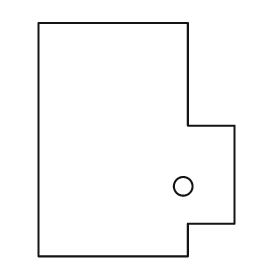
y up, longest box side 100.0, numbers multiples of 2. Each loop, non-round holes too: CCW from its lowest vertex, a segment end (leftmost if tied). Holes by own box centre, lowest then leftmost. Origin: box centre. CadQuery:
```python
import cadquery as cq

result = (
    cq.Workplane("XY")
    .moveTo(-42.0, -50.0)
    .lineTo(22.0, -50.0)
    .lineTo(22.0, -36.0)
    .lineTo(42.0, -36.0)
    .lineTo(42.0, 6.0)
    .lineTo(22.0, 6.0)
    .lineTo(22.0, 50.0)
    .lineTo(-42.0, 50.0)
    .close()
    .moveTo(20.0, -20.0)
    .circle(4.0)
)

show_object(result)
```